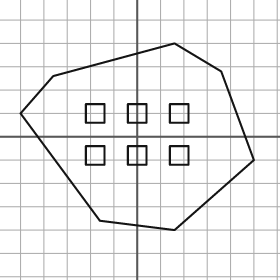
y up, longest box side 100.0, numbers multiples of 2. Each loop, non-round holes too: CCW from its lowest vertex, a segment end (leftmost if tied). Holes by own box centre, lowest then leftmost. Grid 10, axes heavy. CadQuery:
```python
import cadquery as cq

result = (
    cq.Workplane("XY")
    .moveTo(16.0, -40.0)
    .lineTo(50.0, -10.0)
    .lineTo(36.0, 28.0)
    .lineTo(16.0, 40.0)
    .lineTo(-36.0, 26.0)
    .lineTo(-50.0, 10.0)
    .lineTo(-16.0, -36.0)
    .close()
    .moveTo(-22.0, -12.0)
    .lineTo(-14.0, -12.0)
    .lineTo(-14.0, -4.0)
    .lineTo(-22.0, -4.0)
    .close()
    .moveTo(-4.0, -12.0)
    .lineTo(4.0, -12.0)
    .lineTo(4.0, -4.0)
    .lineTo(-4.0, -4.0)
    .close()
    .moveTo(14.0, -12.0)
    .lineTo(22.0, -12.0)
    .lineTo(22.0, -4.0)
    .lineTo(14.0, -4.0)
    .close()
    .moveTo(-22.0, 6.0)
    .lineTo(-14.0, 6.0)
    .lineTo(-14.0, 14.0)
    .lineTo(-22.0, 14.0)
    .close()
    .moveTo(-4.0, 6.0)
    .lineTo(4.0, 6.0)
    .lineTo(4.0, 14.0)
    .lineTo(-4.0, 14.0)
    .close()
    .moveTo(14.0, 6.0)
    .lineTo(22.0, 6.0)
    .lineTo(22.0, 14.0)
    .lineTo(14.0, 14.0)
    .close()
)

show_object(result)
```